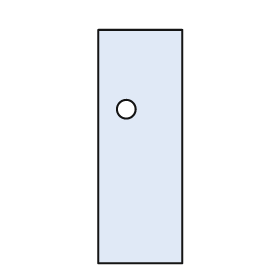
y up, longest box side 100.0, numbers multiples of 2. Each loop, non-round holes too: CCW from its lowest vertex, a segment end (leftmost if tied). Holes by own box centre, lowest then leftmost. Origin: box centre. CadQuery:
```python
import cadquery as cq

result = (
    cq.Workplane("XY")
    .moveTo(-18.0, -50.0)
    .lineTo(18.0, -50.0)
    .lineTo(18.0, 50.0)
    .lineTo(-18.0, 50.0)
    .close()
    .moveTo(-6.0, 16.0)
    .circle(4.0)
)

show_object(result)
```